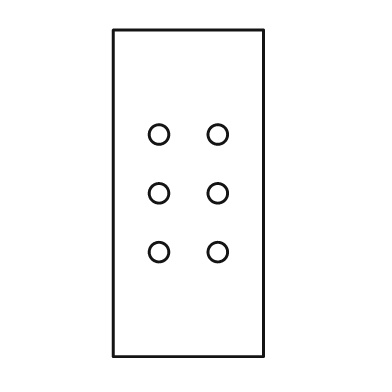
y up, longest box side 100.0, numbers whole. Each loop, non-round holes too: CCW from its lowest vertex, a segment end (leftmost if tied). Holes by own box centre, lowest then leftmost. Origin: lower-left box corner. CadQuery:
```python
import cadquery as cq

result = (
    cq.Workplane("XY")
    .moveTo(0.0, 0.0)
    .lineTo(46.0, 0.0)
    .lineTo(46.0, 100.0)
    .lineTo(0.0, 100.0)
    .close()
    .moveTo(14.0, 32.0)
    .circle(3.0)
    .moveTo(32.0, 32.0)
    .circle(3.0)
    .moveTo(14.0, 50.0)
    .circle(3.0)
    .moveTo(32.0, 50.0)
    .circle(3.0)
    .moveTo(14.0, 68.0)
    .circle(3.0)
    .moveTo(32.0, 68.0)
    .circle(3.0)
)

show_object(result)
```